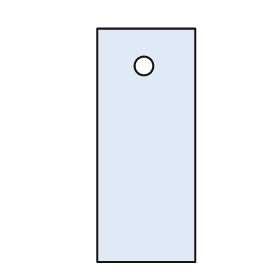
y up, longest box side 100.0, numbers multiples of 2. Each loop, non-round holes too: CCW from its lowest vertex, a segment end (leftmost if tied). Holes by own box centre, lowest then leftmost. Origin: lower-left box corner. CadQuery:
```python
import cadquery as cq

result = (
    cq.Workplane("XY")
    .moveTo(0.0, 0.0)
    .lineTo(42.0, 0.0)
    .lineTo(42.0, 100.0)
    .lineTo(0.0, 100.0)
    .close()
    .moveTo(20.0, 84.0)
    .circle(4.0)
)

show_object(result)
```